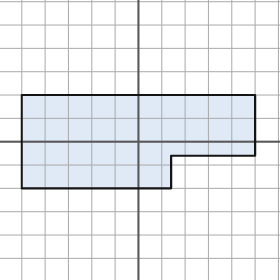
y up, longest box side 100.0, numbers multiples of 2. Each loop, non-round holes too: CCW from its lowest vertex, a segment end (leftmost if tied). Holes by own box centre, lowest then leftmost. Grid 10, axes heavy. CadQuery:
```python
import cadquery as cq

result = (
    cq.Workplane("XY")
    .moveTo(-50.0, -20.0)
    .lineTo(14.0, -20.0)
    .lineTo(14.0, -6.0)
    .lineTo(50.0, -6.0)
    .lineTo(50.0, 20.0)
    .lineTo(-50.0, 20.0)
    .close()
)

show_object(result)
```